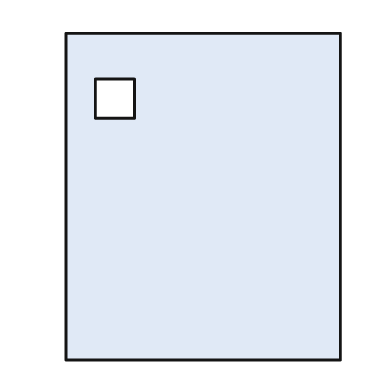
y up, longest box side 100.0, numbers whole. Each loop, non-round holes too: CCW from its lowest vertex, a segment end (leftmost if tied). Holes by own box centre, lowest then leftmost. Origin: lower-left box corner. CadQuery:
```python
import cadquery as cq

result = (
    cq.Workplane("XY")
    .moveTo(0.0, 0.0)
    .lineTo(84.0, 0.0)
    .lineTo(84.0, 100.0)
    .lineTo(0.0, 100.0)
    .close()
    .moveTo(9.0, 74.0)
    .lineTo(21.0, 74.0)
    .lineTo(21.0, 86.0)
    .lineTo(9.0, 86.0)
    .close()
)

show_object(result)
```